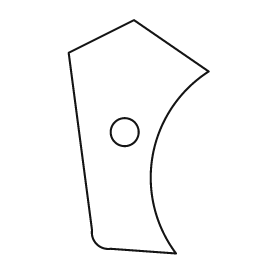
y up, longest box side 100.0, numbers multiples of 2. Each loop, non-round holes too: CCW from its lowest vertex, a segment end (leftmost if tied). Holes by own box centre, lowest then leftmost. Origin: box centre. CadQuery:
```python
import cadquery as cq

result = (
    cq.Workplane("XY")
    .moveTo(16.0, -50.0)
    .threePointArc((6.0, -8.0), (30.0, 28.0))
    .lineTo(-2.0, 50.0)
    .lineTo(-30.0, 36.0)
    .lineTo(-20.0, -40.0)
    .threePointArc((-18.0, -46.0), (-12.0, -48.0))
    .close()
    .moveTo(-6.0, 2.0)
    .circle(6.0)
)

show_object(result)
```